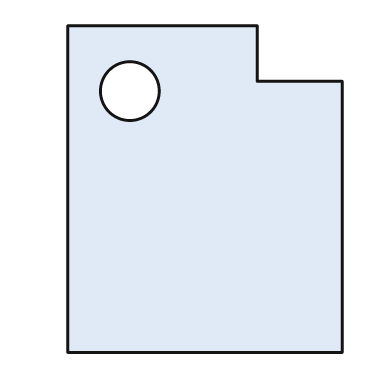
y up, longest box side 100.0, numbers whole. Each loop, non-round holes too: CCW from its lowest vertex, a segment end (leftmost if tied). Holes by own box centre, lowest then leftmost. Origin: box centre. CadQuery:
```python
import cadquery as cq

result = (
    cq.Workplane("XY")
    .moveTo(-42.0, -50.0)
    .lineTo(42.0, -50.0)
    .lineTo(42.0, 33.0)
    .lineTo(16.0, 33.0)
    .lineTo(16.0, 50.0)
    .lineTo(-42.0, 50.0)
    .close()
    .moveTo(-23.0, 30.0)
    .circle(9.0)
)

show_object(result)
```